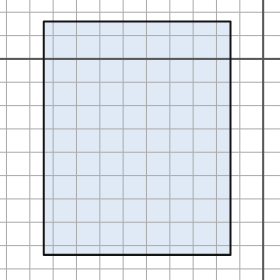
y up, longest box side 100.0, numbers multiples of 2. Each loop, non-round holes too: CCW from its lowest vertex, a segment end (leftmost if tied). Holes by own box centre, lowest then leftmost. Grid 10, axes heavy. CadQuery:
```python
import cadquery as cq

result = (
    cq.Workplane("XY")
    .moveTo(-94.0, -84.0)
    .lineTo(-14.0, -84.0)
    .lineTo(-14.0, 16.0)
    .lineTo(-94.0, 16.0)
    .close()
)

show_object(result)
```